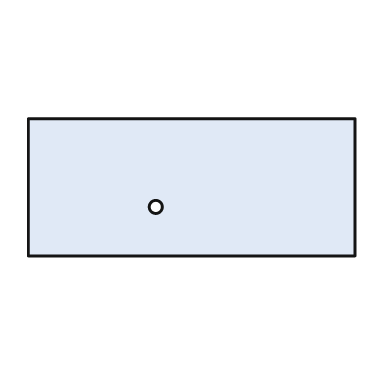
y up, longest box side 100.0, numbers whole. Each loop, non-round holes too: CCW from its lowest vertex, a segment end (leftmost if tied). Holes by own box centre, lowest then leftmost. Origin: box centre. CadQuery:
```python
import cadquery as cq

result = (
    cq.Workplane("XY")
    .moveTo(-50.0, -21.0)
    .lineTo(50.0, -21.0)
    .lineTo(50.0, 21.0)
    .lineTo(-50.0, 21.0)
    .close()
    .moveTo(-11.0, -6.0)
    .circle(2.0)
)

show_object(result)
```